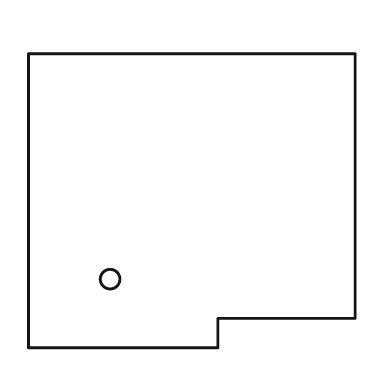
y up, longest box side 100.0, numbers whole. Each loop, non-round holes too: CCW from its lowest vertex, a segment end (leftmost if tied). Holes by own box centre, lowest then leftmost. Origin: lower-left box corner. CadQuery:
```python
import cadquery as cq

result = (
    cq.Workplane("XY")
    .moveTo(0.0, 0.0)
    .lineTo(58.0, 0.0)
    .lineTo(58.0, 9.0)
    .lineTo(100.0, 9.0)
    .lineTo(100.0, 90.0)
    .lineTo(0.0, 90.0)
    .close()
    .moveTo(25.0, 21.0)
    .circle(3.0)
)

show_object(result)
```